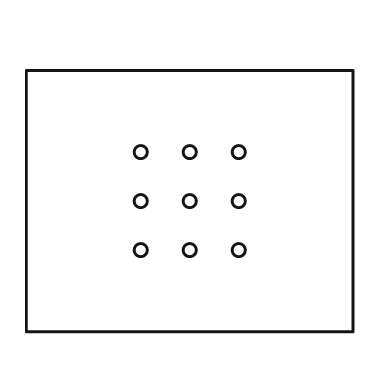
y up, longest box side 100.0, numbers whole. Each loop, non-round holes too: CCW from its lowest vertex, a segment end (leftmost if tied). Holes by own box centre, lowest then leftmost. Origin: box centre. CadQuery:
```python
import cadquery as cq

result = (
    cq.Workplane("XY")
    .moveTo(-50.0, -40.0)
    .lineTo(50.0, -40.0)
    .lineTo(50.0, 40.0)
    .lineTo(-50.0, 40.0)
    .close()
    .moveTo(-15.0, -15.0)
    .circle(2.0)
    .moveTo(0.0, -15.0)
    .circle(2.0)
    .moveTo(15.0, -15.0)
    .circle(2.0)
    .moveTo(-15.0, 0.0)
    .circle(2.0)
    .moveTo(0.0, 0.0)
    .circle(2.0)
    .moveTo(15.0, 0.0)
    .circle(2.0)
    .moveTo(-15.0, 15.0)
    .circle(2.0)
    .moveTo(0.0, 15.0)
    .circle(2.0)
    .moveTo(15.0, 15.0)
    .circle(2.0)
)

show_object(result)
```